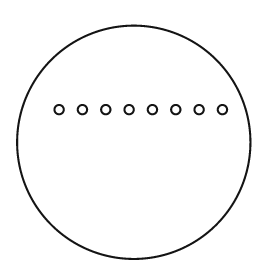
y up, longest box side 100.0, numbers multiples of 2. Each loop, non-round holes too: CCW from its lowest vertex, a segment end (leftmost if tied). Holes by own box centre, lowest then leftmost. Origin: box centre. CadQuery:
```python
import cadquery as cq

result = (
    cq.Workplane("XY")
    .moveTo(0.0, 0.0)
    .circle(50.0)
    .moveTo(-32.0, 14.0)
    .circle(2.0)
    .moveTo(-22.0, 14.0)
    .circle(2.0)
    .moveTo(-12.0, 14.0)
    .circle(2.0)
    .moveTo(-2.0, 14.0)
    .circle(2.0)
    .moveTo(8.0, 14.0)
    .circle(2.0)
    .moveTo(18.0, 14.0)
    .circle(2.0)
    .moveTo(28.0, 14.0)
    .circle(2.0)
    .moveTo(38.0, 14.0)
    .circle(2.0)
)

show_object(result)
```